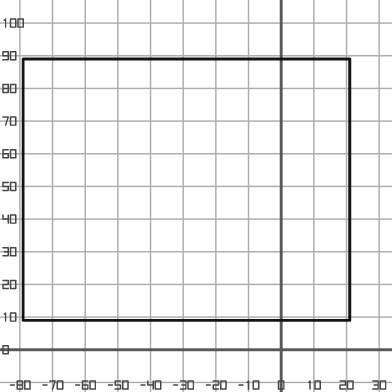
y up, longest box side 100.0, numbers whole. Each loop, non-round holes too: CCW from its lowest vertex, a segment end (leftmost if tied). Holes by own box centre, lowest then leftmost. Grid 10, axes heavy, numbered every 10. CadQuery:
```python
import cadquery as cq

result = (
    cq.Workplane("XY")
    .moveTo(-79.0, 9.0)
    .lineTo(21.0, 9.0)
    .lineTo(21.0, 89.0)
    .lineTo(-79.0, 89.0)
    .close()
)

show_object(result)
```